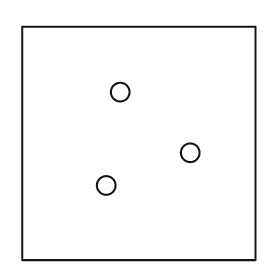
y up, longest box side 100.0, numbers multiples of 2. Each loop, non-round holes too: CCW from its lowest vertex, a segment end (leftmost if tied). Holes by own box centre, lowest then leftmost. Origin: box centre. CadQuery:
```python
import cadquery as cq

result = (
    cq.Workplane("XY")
    .moveTo(-50.0, -50.0)
    .lineTo(50.0, -50.0)
    .lineTo(50.0, 50.0)
    .lineTo(-50.0, 50.0)
    .close()
    .moveTo(-14.0, -18.0)
    .circle(4.0)
    .moveTo(22.0, -4.0)
    .circle(4.0)
    .moveTo(-8.0, 22.0)
    .circle(4.0)
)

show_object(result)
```